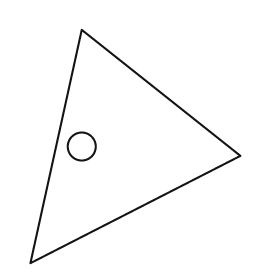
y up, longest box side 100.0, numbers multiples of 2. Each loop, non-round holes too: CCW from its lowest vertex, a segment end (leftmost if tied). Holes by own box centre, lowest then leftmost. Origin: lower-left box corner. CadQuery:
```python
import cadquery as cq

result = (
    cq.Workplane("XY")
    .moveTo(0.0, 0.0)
    .lineTo(90.0, 46.0)
    .lineTo(22.0, 100.0)
    .close()
    .moveTo(22.0, 50.0)
    .circle(6.0)
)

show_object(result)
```